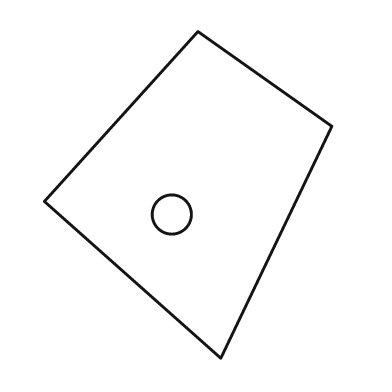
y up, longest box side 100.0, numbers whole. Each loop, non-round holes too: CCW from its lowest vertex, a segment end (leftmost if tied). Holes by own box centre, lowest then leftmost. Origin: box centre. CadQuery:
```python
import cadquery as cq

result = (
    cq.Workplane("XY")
    .moveTo(10.0, -50.0)
    .lineTo(44.0, 21.0)
    .lineTo(3.0, 50.0)
    .lineTo(-44.0, -2.0)
    .close()
    .moveTo(-5.0, -6.0)
    .circle(6.0)
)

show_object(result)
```